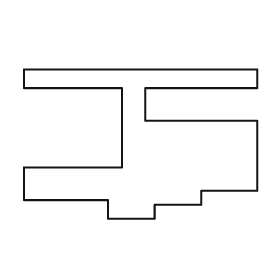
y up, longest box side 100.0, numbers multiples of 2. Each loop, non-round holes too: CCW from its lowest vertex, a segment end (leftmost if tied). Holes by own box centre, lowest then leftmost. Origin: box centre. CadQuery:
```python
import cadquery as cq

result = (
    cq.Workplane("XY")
    .moveTo(-14.0, -32.0)
    .lineTo(6.0, -32.0)
    .lineTo(6.0, -26.0)
    .lineTo(26.0, -26.0)
    .lineTo(26.0, -20.0)
    .lineTo(50.0, -20.0)
    .lineTo(50.0, 10.0)
    .lineTo(2.0, 10.0)
    .lineTo(2.0, 24.0)
    .lineTo(50.0, 24.0)
    .lineTo(50.0, 32.0)
    .lineTo(-50.0, 32.0)
    .lineTo(-50.0, 24.0)
    .lineTo(-8.0, 24.0)
    .lineTo(-8.0, -10.0)
    .lineTo(-50.0, -10.0)
    .lineTo(-50.0, -24.0)
    .lineTo(-14.0, -24.0)
    .close()
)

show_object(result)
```